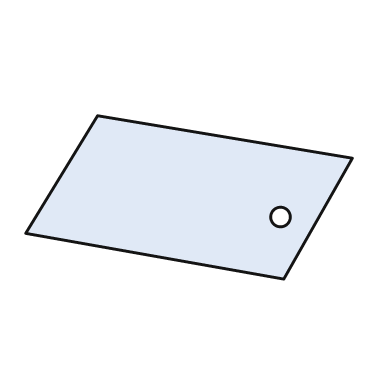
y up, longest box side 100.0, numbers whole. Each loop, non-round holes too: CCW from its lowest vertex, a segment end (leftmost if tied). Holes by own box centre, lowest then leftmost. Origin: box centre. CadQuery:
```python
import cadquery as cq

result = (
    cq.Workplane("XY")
    .moveTo(29.0, -25.0)
    .lineTo(50.0, 12.0)
    .lineTo(-28.0, 25.0)
    .lineTo(-50.0, -11.0)
    .close()
    .moveTo(28.0, -6.0)
    .circle(3.0)
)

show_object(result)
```